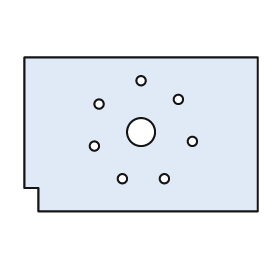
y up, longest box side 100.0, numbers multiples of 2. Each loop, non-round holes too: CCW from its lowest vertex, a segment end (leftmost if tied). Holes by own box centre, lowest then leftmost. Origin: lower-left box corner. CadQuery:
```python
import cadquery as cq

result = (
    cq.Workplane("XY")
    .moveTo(6.0, 0.0)
    .lineTo(100.0, 0.0)
    .lineTo(100.0, 66.0)
    .lineTo(0.0, 66.0)
    .lineTo(0.0, 10.0)
    .lineTo(6.0, 10.0)
    .close()
    .moveTo(42.0, 14.0)
    .circle(2.0)
    .moveTo(60.0, 14.0)
    .circle(2.0)
    .moveTo(30.0, 28.0)
    .circle(2.0)
    .moveTo(72.0, 30.0)
    .circle(2.0)
    .moveTo(50.0, 34.0)
    .circle(6.0)
    .moveTo(32.0, 46.0)
    .circle(2.0)
    .moveTo(66.0, 48.0)
    .circle(2.0)
    .moveTo(50.0, 56.0)
    .circle(2.0)
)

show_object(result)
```